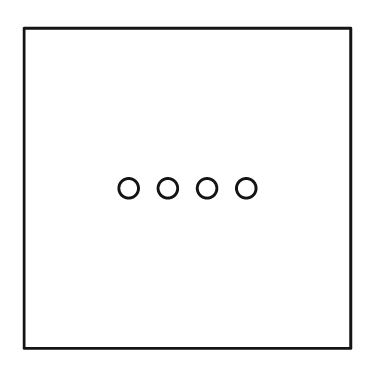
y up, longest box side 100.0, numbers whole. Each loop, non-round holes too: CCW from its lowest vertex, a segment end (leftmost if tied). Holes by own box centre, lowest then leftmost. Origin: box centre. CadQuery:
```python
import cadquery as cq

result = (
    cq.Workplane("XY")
    .moveTo(-50.0, -49.0)
    .lineTo(50.0, -49.0)
    .lineTo(50.0, 49.0)
    .lineTo(-50.0, 49.0)
    .close()
    .moveTo(-18.0, 0.0)
    .circle(3.0)
    .moveTo(-6.0, 0.0)
    .circle(3.0)
    .moveTo(6.0, 0.0)
    .circle(3.0)
    .moveTo(18.0, 0.0)
    .circle(3.0)
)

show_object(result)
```